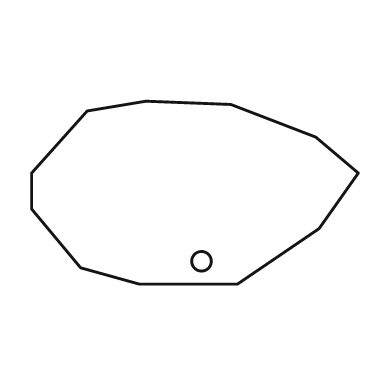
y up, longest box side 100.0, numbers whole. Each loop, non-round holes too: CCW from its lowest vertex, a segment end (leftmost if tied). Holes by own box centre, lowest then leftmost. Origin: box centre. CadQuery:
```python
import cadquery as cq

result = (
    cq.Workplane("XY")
    .moveTo(-17.0, -28.0)
    .lineTo(13.0, -28.0)
    .lineTo(38.0, -11.0)
    .lineTo(50.0, 6.0)
    .lineTo(37.0, 17.0)
    .lineTo(11.0, 27.0)
    .lineTo(-15.0, 28.0)
    .lineTo(-33.0, 25.0)
    .lineTo(-50.0, 6.0)
    .lineTo(-50.0, -5.0)
    .lineTo(-35.0, -23.0)
    .close()
    .moveTo(2.0, -21.0)
    .circle(3.0)
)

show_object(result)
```